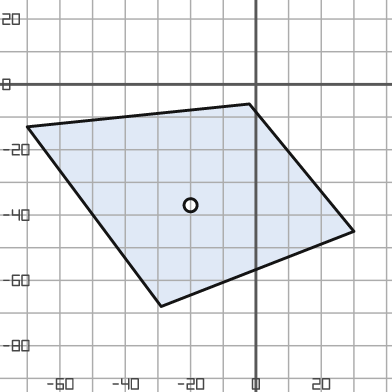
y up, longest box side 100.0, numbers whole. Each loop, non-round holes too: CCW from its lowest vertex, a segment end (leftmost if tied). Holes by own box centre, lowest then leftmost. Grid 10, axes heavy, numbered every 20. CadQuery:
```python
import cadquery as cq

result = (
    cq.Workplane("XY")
    .moveTo(-29.0, -68.0)
    .lineTo(30.0, -45.0)
    .lineTo(-2.0, -6.0)
    .lineTo(-70.0, -13.0)
    .close()
    .moveTo(-20.0, -37.0)
    .circle(2.0)
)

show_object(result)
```